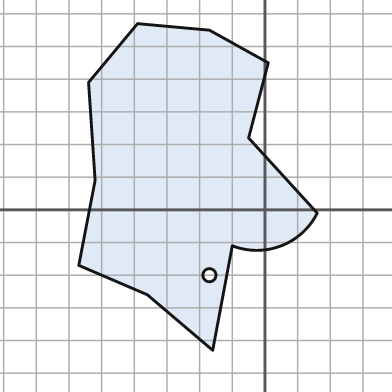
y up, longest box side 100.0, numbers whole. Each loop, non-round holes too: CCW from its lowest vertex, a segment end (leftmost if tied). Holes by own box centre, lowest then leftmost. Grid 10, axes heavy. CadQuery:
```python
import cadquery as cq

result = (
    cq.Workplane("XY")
    .moveTo(-16.0, -43.0)
    .lineTo(-10.0, -11.0)
    .threePointArc((5.0, -11.0), (16.0, -1.0))
    .lineTo(-5.0, 22.0)
    .lineTo(1.0, 45.0)
    .lineTo(-17.0, 55.0)
    .lineTo(-39.0, 57.0)
    .lineTo(-54.0, 39.0)
    .lineTo(-52.0, 9.0)
    .lineTo(-57.0, -17.0)
    .lineTo(-36.0, -26.0)
    .close()
    .moveTo(-17.0, -20.0)
    .circle(2.0)
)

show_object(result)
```